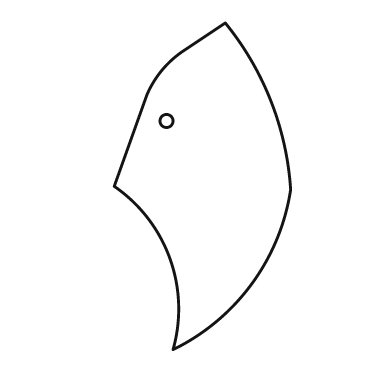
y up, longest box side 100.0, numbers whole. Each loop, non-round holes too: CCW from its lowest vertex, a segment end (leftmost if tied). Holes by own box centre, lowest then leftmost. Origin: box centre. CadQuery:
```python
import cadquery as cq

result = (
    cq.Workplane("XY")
    .moveTo(-9.0, -50.0)
    .threePointArc((15.0, -30.0), (27.0, -1.0))
    .threePointArc((21.0, 26.0), (7.0, 50.0))
    .lineTo(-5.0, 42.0)
    .threePointArc((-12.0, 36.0), (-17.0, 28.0))
    .lineTo(-27.0, 0.0)
    .threePointArc((-10.0, -22.0), (-9.0, -50.0))
    .close()
    .moveTo(-11.0, 20.0)
    .circle(2.0)
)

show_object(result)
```